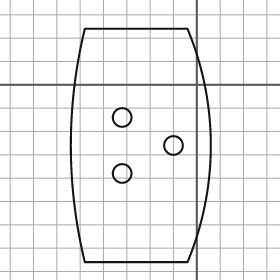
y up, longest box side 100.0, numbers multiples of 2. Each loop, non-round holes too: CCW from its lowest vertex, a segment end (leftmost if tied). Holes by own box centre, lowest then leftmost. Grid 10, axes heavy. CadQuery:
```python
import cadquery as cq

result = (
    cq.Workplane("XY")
    .moveTo(-48.0, -76.0)
    .lineTo(-4.0, -76.0)
    .threePointArc((6.0, -26.0), (-4.0, 24.0))
    .lineTo(-48.0, 24.0)
    .threePointArc((-54.0, -26.0), (-48.0, -76.0))
    .close()
    .moveTo(-32.0, -38.0)
    .circle(4.0)
    .moveTo(-10.0, -26.0)
    .circle(4.0)
    .moveTo(-32.0, -14.0)
    .circle(4.0)
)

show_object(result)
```